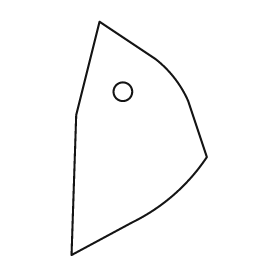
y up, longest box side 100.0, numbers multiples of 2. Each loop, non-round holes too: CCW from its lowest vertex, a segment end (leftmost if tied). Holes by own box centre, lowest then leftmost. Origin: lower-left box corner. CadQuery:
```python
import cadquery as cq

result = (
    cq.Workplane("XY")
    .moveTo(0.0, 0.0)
    .lineTo(26.0, 14.0)
    .threePointArc((44.0, 26.0), (58.0, 42.0))
    .lineTo(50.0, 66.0)
    .threePointArc((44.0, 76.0), (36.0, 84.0))
    .lineTo(12.0, 100.0)
    .lineTo(2.0, 60.0)
    .close()
    .moveTo(22.0, 70.0)
    .circle(4.0)
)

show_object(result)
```